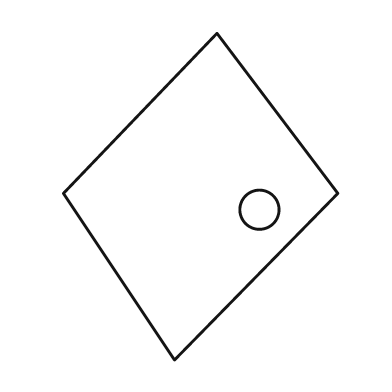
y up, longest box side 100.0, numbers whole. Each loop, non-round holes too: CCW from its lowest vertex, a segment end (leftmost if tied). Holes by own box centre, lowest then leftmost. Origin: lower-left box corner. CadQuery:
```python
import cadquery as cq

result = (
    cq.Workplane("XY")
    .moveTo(34.0, 0.0)
    .lineTo(84.0, 51.0)
    .lineTo(47.0, 100.0)
    .lineTo(0.0, 51.0)
    .close()
    .moveTo(60.0, 46.0)
    .circle(6.0)
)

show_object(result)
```